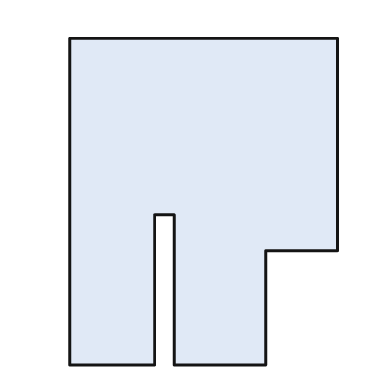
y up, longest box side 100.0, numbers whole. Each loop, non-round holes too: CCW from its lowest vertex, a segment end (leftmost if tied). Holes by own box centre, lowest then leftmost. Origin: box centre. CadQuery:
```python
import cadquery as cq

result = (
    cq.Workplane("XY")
    .moveTo(-41.0, -50.0)
    .lineTo(-15.0, -50.0)
    .lineTo(-15.0, -4.0)
    .lineTo(-9.0, -4.0)
    .lineTo(-9.0, -50.0)
    .lineTo(19.0, -50.0)
    .lineTo(19.0, -15.0)
    .lineTo(41.0, -15.0)
    .lineTo(41.0, 50.0)
    .lineTo(-41.0, 50.0)
    .close()
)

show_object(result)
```